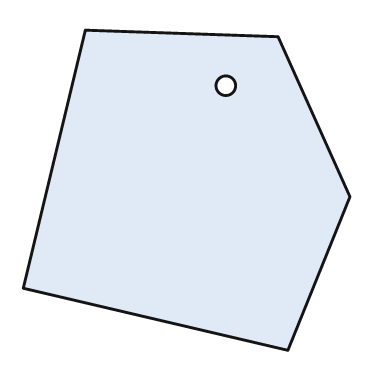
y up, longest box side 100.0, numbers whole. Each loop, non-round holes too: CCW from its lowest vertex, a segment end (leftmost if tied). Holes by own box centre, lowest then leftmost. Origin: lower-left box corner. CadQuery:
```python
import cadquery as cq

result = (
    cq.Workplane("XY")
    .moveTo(81.0, 0.0)
    .lineTo(100.0, 47.0)
    .lineTo(78.0, 96.0)
    .lineTo(19.0, 98.0)
    .lineTo(0.0, 19.0)
    .close()
    .moveTo(62.0, 81.0)
    .circle(3.0)
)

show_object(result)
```